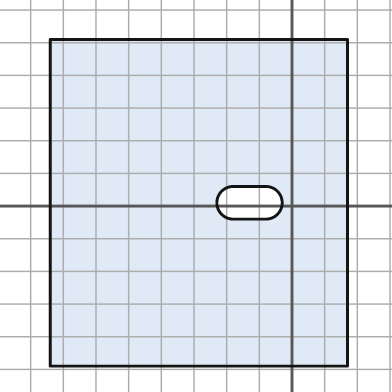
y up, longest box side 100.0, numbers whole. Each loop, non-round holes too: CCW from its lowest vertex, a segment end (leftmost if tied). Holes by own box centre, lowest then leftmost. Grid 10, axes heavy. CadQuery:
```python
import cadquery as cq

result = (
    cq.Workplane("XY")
    .moveTo(-74.0, -49.0)
    .lineTo(17.0, -49.0)
    .lineTo(17.0, 51.0)
    .lineTo(-74.0, 51.0)
    .close()
    .moveTo(-18.0, -4.0)
    .lineTo(-8.0, -4.0)
    .threePointArc((-3.0, 1.0), (-8.0, 6.0))
    .lineTo(-18.0, 6.0)
    .threePointArc((-23.0, 1.0), (-18.0, -4.0))
    .close()
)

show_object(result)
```